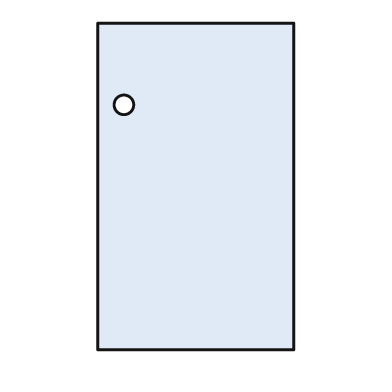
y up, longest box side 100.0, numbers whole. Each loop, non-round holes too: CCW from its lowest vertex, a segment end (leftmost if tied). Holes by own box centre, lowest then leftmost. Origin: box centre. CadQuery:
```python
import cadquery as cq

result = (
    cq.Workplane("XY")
    .moveTo(-30.0, -50.0)
    .lineTo(30.0, -50.0)
    .lineTo(30.0, 50.0)
    .lineTo(-30.0, 50.0)
    .close()
    .moveTo(-22.0, 25.0)
    .circle(3.0)
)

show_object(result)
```